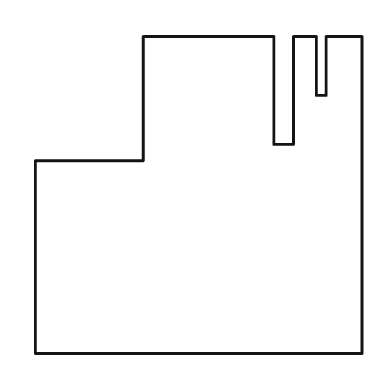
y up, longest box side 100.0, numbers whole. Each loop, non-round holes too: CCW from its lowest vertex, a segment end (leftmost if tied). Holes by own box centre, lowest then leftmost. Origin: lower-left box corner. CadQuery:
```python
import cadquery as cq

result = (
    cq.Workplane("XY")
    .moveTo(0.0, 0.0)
    .lineTo(100.0, 0.0)
    .lineTo(100.0, 97.0)
    .lineTo(89.0, 97.0)
    .lineTo(89.0, 79.0)
    .lineTo(86.0, 79.0)
    .lineTo(86.0, 97.0)
    .lineTo(79.0, 97.0)
    .lineTo(79.0, 64.0)
    .lineTo(73.0, 64.0)
    .lineTo(73.0, 97.0)
    .lineTo(33.0, 97.0)
    .lineTo(33.0, 59.0)
    .lineTo(0.0, 59.0)
    .close()
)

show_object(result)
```